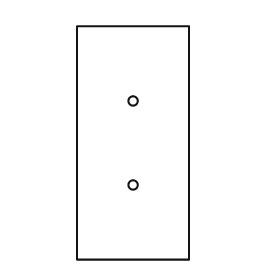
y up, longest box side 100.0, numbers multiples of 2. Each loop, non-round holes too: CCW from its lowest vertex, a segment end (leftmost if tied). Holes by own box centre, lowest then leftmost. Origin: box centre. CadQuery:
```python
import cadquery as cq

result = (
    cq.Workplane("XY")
    .moveTo(-24.0, -50.0)
    .lineTo(24.0, -50.0)
    .lineTo(24.0, 50.0)
    .lineTo(-24.0, 50.0)
    .close()
    .moveTo(0.0, -18.0)
    .circle(2.0)
    .moveTo(0.0, 18.0)
    .circle(2.0)
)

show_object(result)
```